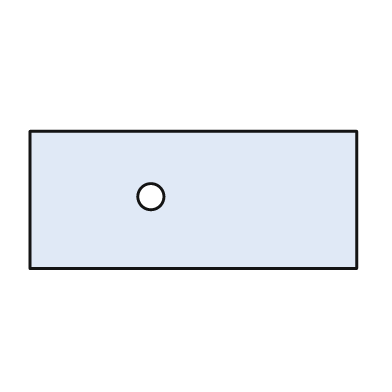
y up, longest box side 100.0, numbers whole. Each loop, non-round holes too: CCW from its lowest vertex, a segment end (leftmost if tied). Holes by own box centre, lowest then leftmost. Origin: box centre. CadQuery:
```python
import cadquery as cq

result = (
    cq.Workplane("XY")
    .moveTo(-50.0, -21.0)
    .lineTo(50.0, -21.0)
    .lineTo(50.0, 21.0)
    .lineTo(-50.0, 21.0)
    .close()
    .moveTo(-13.0, 1.0)
    .circle(4.0)
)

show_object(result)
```